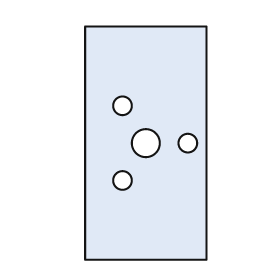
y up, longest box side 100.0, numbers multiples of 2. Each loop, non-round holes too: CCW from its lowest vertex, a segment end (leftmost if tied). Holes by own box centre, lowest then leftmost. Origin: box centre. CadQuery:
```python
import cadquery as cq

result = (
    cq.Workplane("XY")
    .moveTo(-26.0, -50.0)
    .lineTo(26.0, -50.0)
    .lineTo(26.0, 50.0)
    .lineTo(-26.0, 50.0)
    .close()
    .moveTo(-10.0, -16.0)
    .circle(4.0)
    .moveTo(0.0, 0.0)
    .circle(6.0)
    .moveTo(18.0, 0.0)
    .circle(4.0)
    .moveTo(-10.0, 16.0)
    .circle(4.0)
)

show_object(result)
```